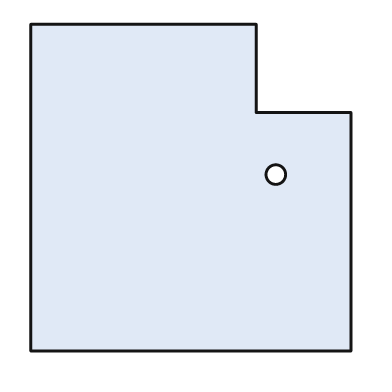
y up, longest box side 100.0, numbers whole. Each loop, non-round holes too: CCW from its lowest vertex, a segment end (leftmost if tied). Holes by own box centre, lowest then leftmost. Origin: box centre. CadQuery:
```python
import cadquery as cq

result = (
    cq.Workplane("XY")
    .moveTo(-49.0, -50.0)
    .lineTo(49.0, -50.0)
    .lineTo(49.0, 23.0)
    .lineTo(20.0, 23.0)
    .lineTo(20.0, 50.0)
    .lineTo(-49.0, 50.0)
    .close()
    .moveTo(26.0, 4.0)
    .circle(3.0)
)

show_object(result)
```